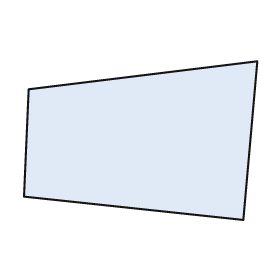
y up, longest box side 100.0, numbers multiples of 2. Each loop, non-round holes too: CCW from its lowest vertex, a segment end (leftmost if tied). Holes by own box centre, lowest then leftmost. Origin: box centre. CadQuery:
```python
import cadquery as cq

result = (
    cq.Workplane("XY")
    .moveTo(44.0, -34.0)
    .lineTo(50.0, 34.0)
    .lineTo(-48.0, 22.0)
    .lineTo(-50.0, -24.0)
    .close()
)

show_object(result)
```